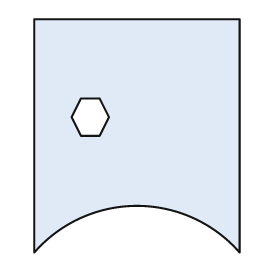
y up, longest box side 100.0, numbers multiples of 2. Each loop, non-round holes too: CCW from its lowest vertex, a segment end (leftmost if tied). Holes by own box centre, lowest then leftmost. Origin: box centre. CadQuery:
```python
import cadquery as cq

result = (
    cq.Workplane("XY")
    .moveTo(-44.0, -50.0)
    .threePointArc((0.0, -30.0), (44.0, -50.0))
    .lineTo(44.0, 50.0)
    .lineTo(-44.0, 50.0)
    .close()
    .moveTo(-24.0, 0.0)
    .lineTo(-16.0, 0.0)
    .lineTo(-12.0, 8.0)
    .lineTo(-16.0, 16.0)
    .lineTo(-24.0, 16.0)
    .lineTo(-28.0, 8.0)
    .close()
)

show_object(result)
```